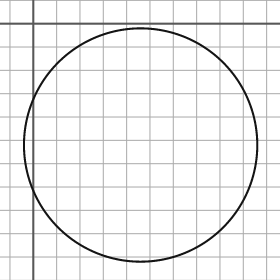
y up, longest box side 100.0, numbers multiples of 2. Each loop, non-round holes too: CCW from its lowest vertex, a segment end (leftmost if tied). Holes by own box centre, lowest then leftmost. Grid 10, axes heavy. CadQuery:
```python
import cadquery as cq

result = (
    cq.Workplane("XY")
    .moveTo(46.0, -52.0)
    .circle(50.0)
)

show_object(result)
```